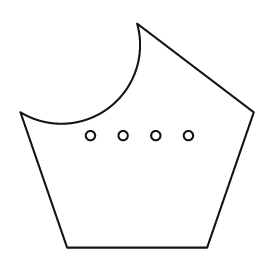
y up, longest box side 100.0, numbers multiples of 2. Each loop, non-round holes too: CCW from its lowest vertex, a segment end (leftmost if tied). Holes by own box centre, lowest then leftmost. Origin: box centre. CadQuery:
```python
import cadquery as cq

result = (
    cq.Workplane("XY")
    .moveTo(-30.0, -48.0)
    .lineTo(30.0, -48.0)
    .lineTo(50.0, 10.0)
    .lineTo(0.0, 48.0)
    .threePointArc((-12.0, 12.0), (-50.0, 10.0))
    .close()
    .moveTo(-20.0, 0.0)
    .circle(2.0)
    .moveTo(-6.0, 0.0)
    .circle(2.0)
    .moveTo(8.0, 0.0)
    .circle(2.0)
    .moveTo(22.0, 0.0)
    .circle(2.0)
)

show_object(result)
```